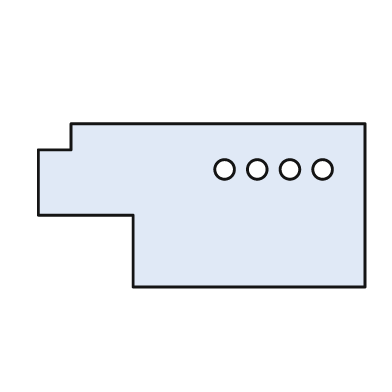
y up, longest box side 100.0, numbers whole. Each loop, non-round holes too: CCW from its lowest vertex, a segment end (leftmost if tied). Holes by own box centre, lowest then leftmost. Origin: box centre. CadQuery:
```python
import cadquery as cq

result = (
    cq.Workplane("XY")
    .moveTo(-21.0, -25.0)
    .lineTo(50.0, -25.0)
    .lineTo(50.0, 25.0)
    .lineTo(-40.0, 25.0)
    .lineTo(-40.0, 17.0)
    .lineTo(-50.0, 17.0)
    .lineTo(-50.0, -3.0)
    .lineTo(-21.0, -3.0)
    .close()
    .moveTo(7.0, 11.0)
    .circle(3.0)
    .moveTo(17.0, 11.0)
    .circle(3.0)
    .moveTo(27.0, 11.0)
    .circle(3.0)
    .moveTo(37.0, 11.0)
    .circle(3.0)
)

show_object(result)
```